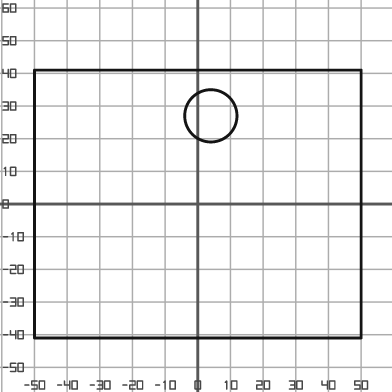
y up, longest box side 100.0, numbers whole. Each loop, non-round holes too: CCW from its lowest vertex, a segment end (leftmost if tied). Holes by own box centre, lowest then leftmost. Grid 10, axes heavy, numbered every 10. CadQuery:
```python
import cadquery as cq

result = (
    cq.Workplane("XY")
    .moveTo(-50.0, -41.0)
    .lineTo(50.0, -41.0)
    .lineTo(50.0, 41.0)
    .lineTo(-50.0, 41.0)
    .close()
    .moveTo(4.0, 27.0)
    .circle(8.0)
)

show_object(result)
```